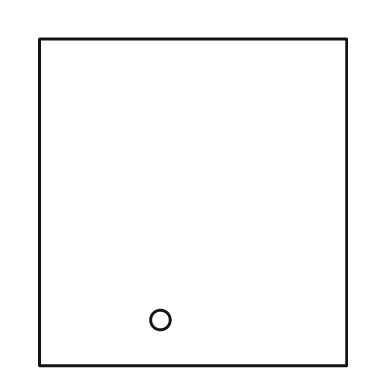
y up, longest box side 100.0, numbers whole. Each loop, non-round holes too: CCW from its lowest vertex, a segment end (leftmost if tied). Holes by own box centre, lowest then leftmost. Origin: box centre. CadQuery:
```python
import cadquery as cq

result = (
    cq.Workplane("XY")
    .moveTo(-47.0, -50.0)
    .lineTo(47.0, -50.0)
    .lineTo(47.0, 50.0)
    .lineTo(-47.0, 50.0)
    .close()
    .moveTo(-10.0, -36.0)
    .circle(3.0)
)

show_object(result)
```